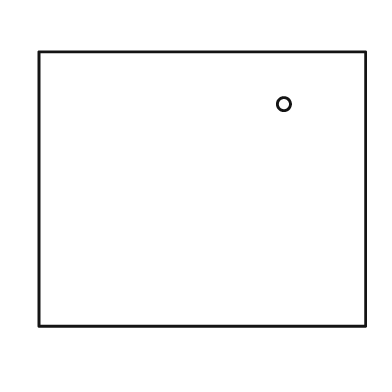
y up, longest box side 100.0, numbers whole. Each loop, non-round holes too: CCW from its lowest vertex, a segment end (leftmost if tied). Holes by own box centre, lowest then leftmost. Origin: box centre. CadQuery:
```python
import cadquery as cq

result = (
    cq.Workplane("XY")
    .moveTo(-50.0, -42.0)
    .lineTo(50.0, -42.0)
    .lineTo(50.0, 42.0)
    .lineTo(-50.0, 42.0)
    .close()
    .moveTo(25.0, 26.0)
    .circle(2.0)
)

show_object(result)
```